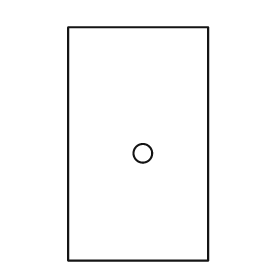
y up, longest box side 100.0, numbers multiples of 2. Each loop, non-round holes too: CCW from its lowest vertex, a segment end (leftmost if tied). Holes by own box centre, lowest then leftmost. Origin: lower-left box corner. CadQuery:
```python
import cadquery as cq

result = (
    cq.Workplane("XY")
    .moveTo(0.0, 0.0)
    .lineTo(60.0, 0.0)
    .lineTo(60.0, 100.0)
    .lineTo(0.0, 100.0)
    .close()
    .moveTo(32.0, 46.0)
    .circle(4.0)
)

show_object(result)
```